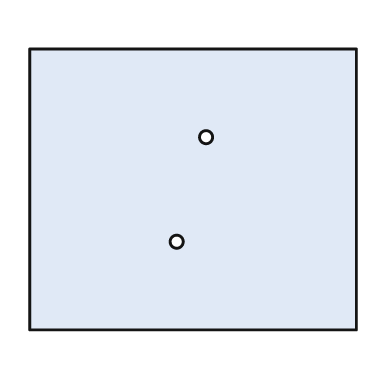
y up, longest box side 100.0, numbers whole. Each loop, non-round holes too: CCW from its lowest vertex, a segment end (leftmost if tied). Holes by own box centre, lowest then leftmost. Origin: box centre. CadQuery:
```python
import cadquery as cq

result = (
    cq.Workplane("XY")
    .moveTo(-50.0, -43.0)
    .lineTo(50.0, -43.0)
    .lineTo(50.0, 43.0)
    .lineTo(-50.0, 43.0)
    .close()
    .moveTo(-5.0, -16.0)
    .circle(2.0)
    .moveTo(4.0, 16.0)
    .circle(2.0)
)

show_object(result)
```